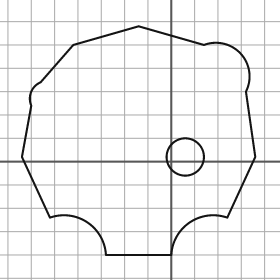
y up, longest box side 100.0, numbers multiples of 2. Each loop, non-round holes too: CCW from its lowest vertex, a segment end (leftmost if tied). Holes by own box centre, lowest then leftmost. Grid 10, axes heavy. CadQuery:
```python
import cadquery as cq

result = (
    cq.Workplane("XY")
    .moveTo(-28.0, -40.0)
    .lineTo(0.0, -40.0)
    .threePointArc((8.0, -26.0), (24.0, -24.0))
    .lineTo(36.0, 2.0)
    .lineTo(32.0, 30.0)
    .threePointArc((30.0, 46.0), (14.0, 50.0))
    .lineTo(-14.0, 58.0)
    .lineTo(-42.0, 50.0)
    .lineTo(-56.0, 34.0)
    .threePointArc((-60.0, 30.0), (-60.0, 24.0))
    .lineTo(-64.0, 2.0)
    .lineTo(-52.0, -24.0)
    .threePointArc((-36.0, -26.0), (-28.0, -40.0))
    .close()
    .moveTo(6.0, 2.0)
    .circle(8.0)
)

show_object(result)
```